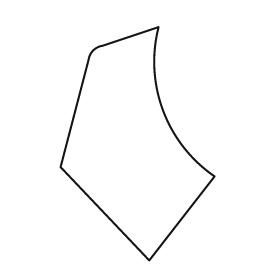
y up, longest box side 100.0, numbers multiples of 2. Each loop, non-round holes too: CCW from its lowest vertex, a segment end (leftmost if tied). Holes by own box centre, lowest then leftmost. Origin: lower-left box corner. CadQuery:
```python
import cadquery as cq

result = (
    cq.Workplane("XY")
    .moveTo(38.0, 0.0)
    .lineTo(66.0, 36.0)
    .threePointArc((44.0, 64.0), (42.0, 100.0))
    .lineTo(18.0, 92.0)
    .threePointArc((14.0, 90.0), (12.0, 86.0))
    .lineTo(0.0, 40.0)
    .close()
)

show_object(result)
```